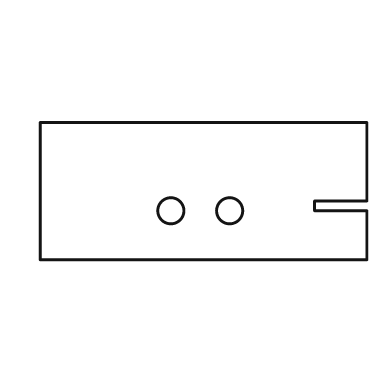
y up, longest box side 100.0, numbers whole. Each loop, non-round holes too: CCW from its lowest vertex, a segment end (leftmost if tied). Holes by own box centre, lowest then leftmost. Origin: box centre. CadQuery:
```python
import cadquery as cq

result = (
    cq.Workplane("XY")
    .moveTo(-50.0, -21.0)
    .lineTo(50.0, -21.0)
    .lineTo(50.0, -6.0)
    .lineTo(34.0, -6.0)
    .lineTo(34.0, -3.0)
    .lineTo(50.0, -3.0)
    .lineTo(50.0, 21.0)
    .lineTo(-50.0, 21.0)
    .close()
    .moveTo(-10.0, -6.0)
    .circle(4.0)
    .moveTo(8.0, -6.0)
    .circle(4.0)
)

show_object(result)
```